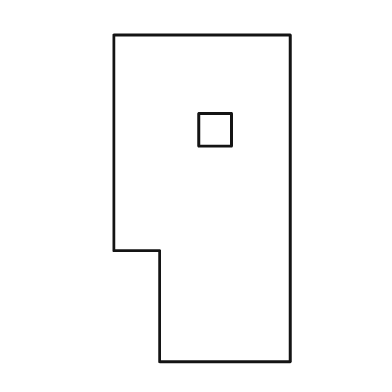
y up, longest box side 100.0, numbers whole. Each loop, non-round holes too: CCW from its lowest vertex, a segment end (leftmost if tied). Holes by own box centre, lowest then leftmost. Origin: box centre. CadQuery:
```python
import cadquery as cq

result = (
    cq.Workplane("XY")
    .moveTo(-13.0, -50.0)
    .lineTo(27.0, -50.0)
    .lineTo(27.0, 50.0)
    .lineTo(-27.0, 50.0)
    .lineTo(-27.0, -16.0)
    .lineTo(-13.0, -16.0)
    .close()
    .moveTo(-1.0, 16.0)
    .lineTo(9.0, 16.0)
    .lineTo(9.0, 26.0)
    .lineTo(-1.0, 26.0)
    .close()
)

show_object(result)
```